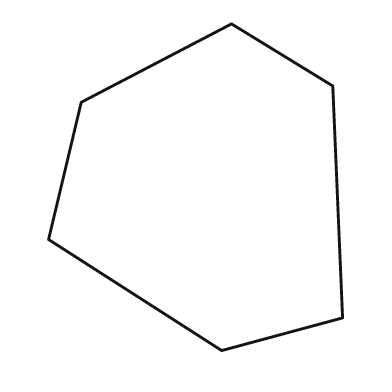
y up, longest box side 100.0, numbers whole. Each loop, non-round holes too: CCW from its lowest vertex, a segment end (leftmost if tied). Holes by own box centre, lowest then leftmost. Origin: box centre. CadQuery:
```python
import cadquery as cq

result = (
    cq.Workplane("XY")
    .moveTo(8.0, -50.0)
    .lineTo(45.0, -40.0)
    .lineTo(42.0, 31.0)
    .lineTo(11.0, 50.0)
    .lineTo(-35.0, 26.0)
    .lineTo(-45.0, -16.0)
    .close()
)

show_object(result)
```